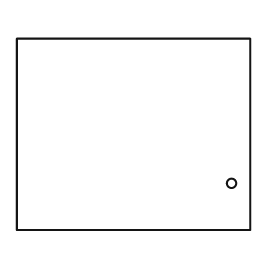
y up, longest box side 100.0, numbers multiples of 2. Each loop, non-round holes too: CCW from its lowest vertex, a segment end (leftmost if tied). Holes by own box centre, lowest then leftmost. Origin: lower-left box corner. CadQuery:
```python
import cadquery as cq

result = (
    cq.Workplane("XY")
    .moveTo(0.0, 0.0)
    .lineTo(100.0, 0.0)
    .lineTo(100.0, 82.0)
    .lineTo(0.0, 82.0)
    .close()
    .moveTo(92.0, 20.0)
    .circle(2.0)
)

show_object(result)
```